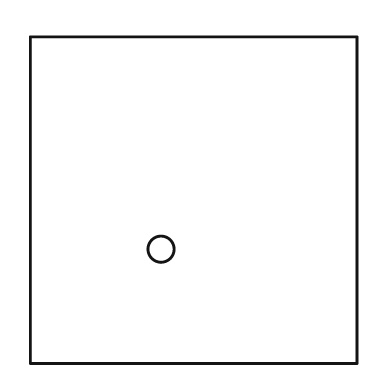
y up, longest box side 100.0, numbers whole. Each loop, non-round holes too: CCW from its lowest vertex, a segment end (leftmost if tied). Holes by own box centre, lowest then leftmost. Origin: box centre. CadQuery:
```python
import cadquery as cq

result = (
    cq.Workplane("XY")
    .moveTo(-50.0, -50.0)
    .lineTo(50.0, -50.0)
    .lineTo(50.0, 50.0)
    .lineTo(-50.0, 50.0)
    .close()
    .moveTo(-10.0, -15.0)
    .circle(4.0)
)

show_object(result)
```